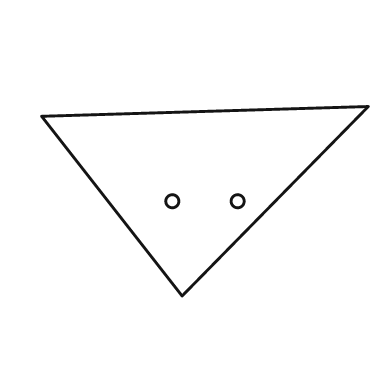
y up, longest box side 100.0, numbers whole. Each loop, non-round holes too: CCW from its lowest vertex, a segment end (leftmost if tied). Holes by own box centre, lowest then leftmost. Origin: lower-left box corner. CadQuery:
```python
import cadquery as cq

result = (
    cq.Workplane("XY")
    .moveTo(43.0, 0.0)
    .lineTo(100.0, 58.0)
    .lineTo(0.0, 55.0)
    .close()
    .moveTo(40.0, 29.0)
    .circle(2.0)
    .moveTo(60.0, 29.0)
    .circle(2.0)
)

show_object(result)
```